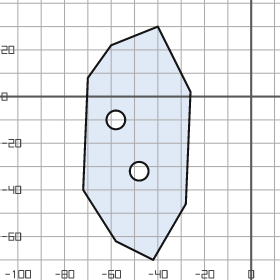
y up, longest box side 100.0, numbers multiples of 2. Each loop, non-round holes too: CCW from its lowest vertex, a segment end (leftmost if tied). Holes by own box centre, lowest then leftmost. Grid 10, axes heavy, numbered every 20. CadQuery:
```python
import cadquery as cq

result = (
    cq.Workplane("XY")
    .moveTo(-42.0, -70.0)
    .lineTo(-28.0, -46.0)
    .lineTo(-26.0, 2.0)
    .lineTo(-40.0, 30.0)
    .lineTo(-60.0, 22.0)
    .lineTo(-70.0, 8.0)
    .lineTo(-72.0, -40.0)
    .lineTo(-58.0, -62.0)
    .close()
    .moveTo(-48.0, -32.0)
    .circle(4.0)
    .moveTo(-58.0, -10.0)
    .circle(4.0)
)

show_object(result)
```